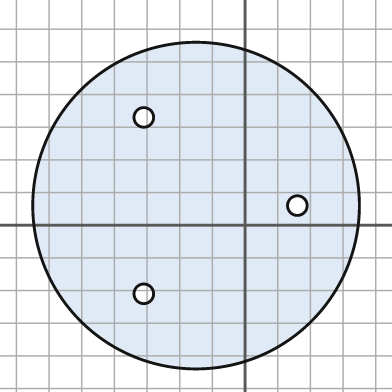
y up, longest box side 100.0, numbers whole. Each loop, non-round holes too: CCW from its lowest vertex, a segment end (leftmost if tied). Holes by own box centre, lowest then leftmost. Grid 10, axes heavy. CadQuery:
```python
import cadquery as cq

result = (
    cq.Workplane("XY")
    .moveTo(-15.0, 6.0)
    .circle(50.0)
    .moveTo(-31.0, -21.0)
    .circle(3.0)
    .moveTo(16.0, 6.0)
    .circle(3.0)
    .moveTo(-31.0, 33.0)
    .circle(3.0)
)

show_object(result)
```